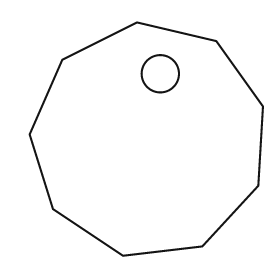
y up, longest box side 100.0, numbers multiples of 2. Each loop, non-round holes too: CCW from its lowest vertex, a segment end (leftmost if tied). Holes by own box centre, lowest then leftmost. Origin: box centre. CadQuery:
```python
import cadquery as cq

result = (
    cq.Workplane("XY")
    .moveTo(-10.0, -50.0)
    .lineTo(24.0, -46.0)
    .lineTo(48.0, -20.0)
    .lineTo(50.0, 14.0)
    .lineTo(30.0, 42.0)
    .lineTo(-4.0, 50.0)
    .lineTo(-36.0, 34.0)
    .lineTo(-50.0, 2.0)
    .lineTo(-40.0, -30.0)
    .close()
    .moveTo(6.0, 28.0)
    .circle(8.0)
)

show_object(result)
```